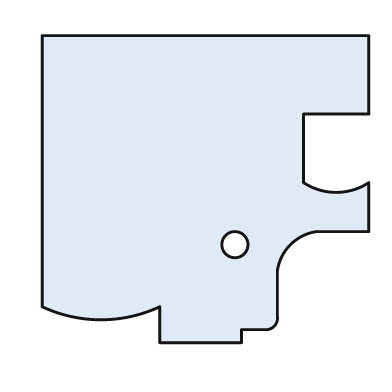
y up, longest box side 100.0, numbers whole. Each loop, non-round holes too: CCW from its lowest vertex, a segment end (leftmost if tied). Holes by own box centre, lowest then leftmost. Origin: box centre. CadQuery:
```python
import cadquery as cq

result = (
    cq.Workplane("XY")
    .moveTo(-14.0, -47.0)
    .lineTo(11.0, -47.0)
    .lineTo(11.0, -43.0)
    .lineTo(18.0, -43.0)
    .threePointArc((21.0, -42.0), (22.0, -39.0))
    .lineTo(22.0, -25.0)
    .threePointArc((26.0, -17.0), (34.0, -13.0))
    .lineTo(50.0, -13.0)
    .lineTo(50.0, 2.0)
    .threePointArc((40.0, -1.0), (30.0, 2.0))
    .lineTo(30.0, 23.0)
    .lineTo(50.0, 23.0)
    .lineTo(50.0, 47.0)
    .lineTo(-50.0, 47.0)
    .lineTo(-50.0, -36.0)
    .threePointArc((-32.0, -40.0), (-14.0, -36.0))
    .close()
    .moveTo(9.0, -17.0)
    .circle(4.0)
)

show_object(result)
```